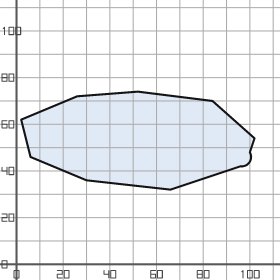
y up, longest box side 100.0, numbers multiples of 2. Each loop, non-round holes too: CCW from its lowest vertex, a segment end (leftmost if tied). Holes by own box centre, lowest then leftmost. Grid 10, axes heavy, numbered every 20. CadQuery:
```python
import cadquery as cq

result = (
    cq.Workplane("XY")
    .moveTo(66.0, 32.0)
    .lineTo(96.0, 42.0)
    .threePointArc((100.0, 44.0), (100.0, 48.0))
    .lineTo(102.0, 54.0)
    .lineTo(84.0, 70.0)
    .lineTo(52.0, 74.0)
    .lineTo(26.0, 72.0)
    .lineTo(2.0, 62.0)
    .lineTo(6.0, 46.0)
    .lineTo(30.0, 36.0)
    .close()
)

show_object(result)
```